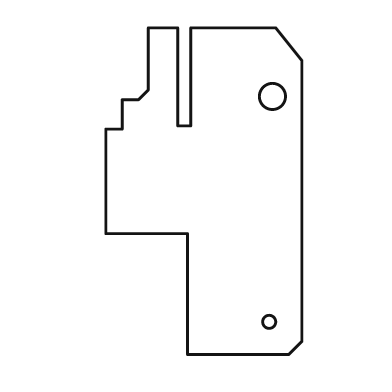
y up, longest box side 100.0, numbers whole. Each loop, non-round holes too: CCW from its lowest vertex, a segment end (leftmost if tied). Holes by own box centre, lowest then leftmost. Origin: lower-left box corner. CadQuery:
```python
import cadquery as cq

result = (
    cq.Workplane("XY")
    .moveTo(25.0, 0.0)
    .lineTo(56.0, 0.0)
    .lineTo(60.0, 4.0)
    .lineTo(60.0, 90.0)
    .lineTo(52.0, 100.0)
    .lineTo(26.0, 100.0)
    .lineTo(26.0, 70.0)
    .lineTo(22.0, 70.0)
    .lineTo(22.0, 100.0)
    .lineTo(13.0, 100.0)
    .lineTo(13.0, 81.0)
    .lineTo(10.0, 78.0)
    .lineTo(5.0, 78.0)
    .lineTo(5.0, 69.0)
    .lineTo(0.0, 69.0)
    .lineTo(0.0, 37.0)
    .lineTo(25.0, 37.0)
    .close()
    .moveTo(50.0, 10.0)
    .circle(2.0)
    .moveTo(51.0, 79.0)
    .circle(4.0)
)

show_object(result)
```